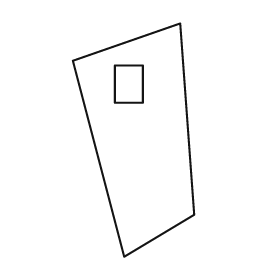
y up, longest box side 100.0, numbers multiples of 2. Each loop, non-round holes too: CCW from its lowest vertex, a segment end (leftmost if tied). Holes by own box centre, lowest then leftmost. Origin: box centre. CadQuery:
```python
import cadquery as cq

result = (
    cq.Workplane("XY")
    .moveTo(-4.0, -50.0)
    .lineTo(26.0, -32.0)
    .lineTo(20.0, 50.0)
    .lineTo(-26.0, 34.0)
    .close()
    .moveTo(-8.0, 16.0)
    .lineTo(4.0, 16.0)
    .lineTo(4.0, 32.0)
    .lineTo(-8.0, 32.0)
    .close()
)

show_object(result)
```